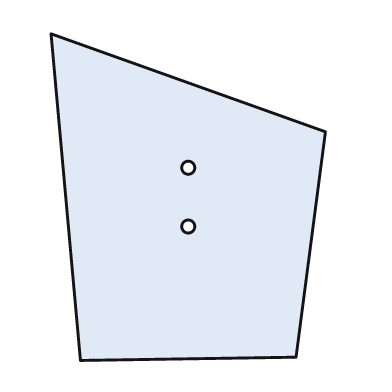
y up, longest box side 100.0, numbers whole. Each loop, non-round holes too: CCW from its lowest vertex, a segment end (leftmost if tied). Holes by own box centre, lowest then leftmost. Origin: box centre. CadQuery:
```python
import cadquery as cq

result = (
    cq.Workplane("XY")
    .moveTo(-33.0, -50.0)
    .lineTo(33.0, -49.0)
    .lineTo(42.0, 20.0)
    .lineTo(-42.0, 50.0)
    .close()
    .moveTo(0.0, -9.0)
    .circle(2.0)
    .moveTo(0.0, 9.0)
    .circle(2.0)
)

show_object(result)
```